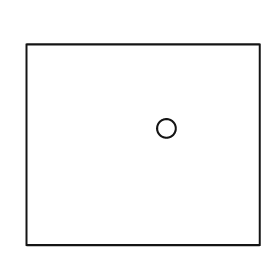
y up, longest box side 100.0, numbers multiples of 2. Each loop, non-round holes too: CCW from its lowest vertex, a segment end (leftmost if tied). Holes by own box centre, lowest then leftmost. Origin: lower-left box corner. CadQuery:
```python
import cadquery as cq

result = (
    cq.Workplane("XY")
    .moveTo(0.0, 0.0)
    .lineTo(100.0, 0.0)
    .lineTo(100.0, 86.0)
    .lineTo(0.0, 86.0)
    .close()
    .moveTo(60.0, 50.0)
    .circle(4.0)
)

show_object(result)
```